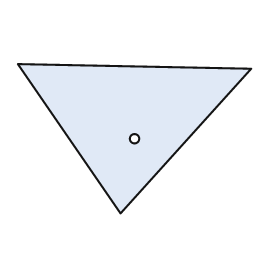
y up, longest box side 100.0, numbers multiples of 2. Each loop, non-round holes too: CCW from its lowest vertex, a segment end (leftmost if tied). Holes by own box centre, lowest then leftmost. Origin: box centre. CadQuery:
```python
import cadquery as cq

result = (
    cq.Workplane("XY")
    .moveTo(-6.0, -32.0)
    .lineTo(50.0, 30.0)
    .lineTo(-50.0, 32.0)
    .close()
    .moveTo(0.0, 0.0)
    .circle(2.0)
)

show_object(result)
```